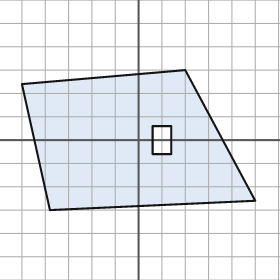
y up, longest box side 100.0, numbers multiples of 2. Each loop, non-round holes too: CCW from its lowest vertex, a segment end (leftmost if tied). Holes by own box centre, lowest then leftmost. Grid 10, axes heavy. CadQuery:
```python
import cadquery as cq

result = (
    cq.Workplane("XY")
    .moveTo(-38.0, -30.0)
    .lineTo(50.0, -26.0)
    .lineTo(20.0, 30.0)
    .lineTo(-50.0, 24.0)
    .close()
    .moveTo(6.0, -6.0)
    .lineTo(14.0, -6.0)
    .lineTo(14.0, 6.0)
    .lineTo(6.0, 6.0)
    .close()
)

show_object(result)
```